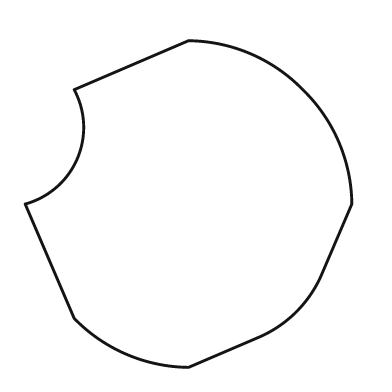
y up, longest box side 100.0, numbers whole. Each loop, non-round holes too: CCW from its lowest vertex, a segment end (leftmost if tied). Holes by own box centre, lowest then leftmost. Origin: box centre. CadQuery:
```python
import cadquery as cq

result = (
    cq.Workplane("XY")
    .moveTo(0.0, -50.0)
    .lineTo(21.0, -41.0)
    .threePointArc((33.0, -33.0), (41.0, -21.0))
    .lineTo(50.0, 0.0)
    .threePointArc((46.0, 19.0), (35.0, 35.0))
    .threePointArc((19.0, 46.0), (0.0, 50.0))
    .lineTo(-35.0, 35.0)
    .threePointArc((-34.0, 14.0), (-50.0, 0.0))
    .lineTo(-35.0, -35.0)
    .threePointArc((-19.0, -46.0), (0.0, -50.0))
    .close()
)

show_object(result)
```